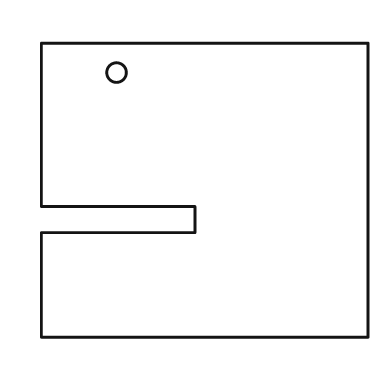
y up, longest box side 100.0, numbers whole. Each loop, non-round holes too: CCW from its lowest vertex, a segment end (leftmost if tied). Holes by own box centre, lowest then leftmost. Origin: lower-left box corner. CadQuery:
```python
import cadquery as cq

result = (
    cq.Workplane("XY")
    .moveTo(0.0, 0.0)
    .lineTo(100.0, 0.0)
    .lineTo(100.0, 90.0)
    .lineTo(0.0, 90.0)
    .lineTo(0.0, 40.0)
    .lineTo(47.0, 40.0)
    .lineTo(47.0, 32.0)
    .lineTo(0.0, 32.0)
    .close()
    .moveTo(23.0, 81.0)
    .circle(3.0)
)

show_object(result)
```